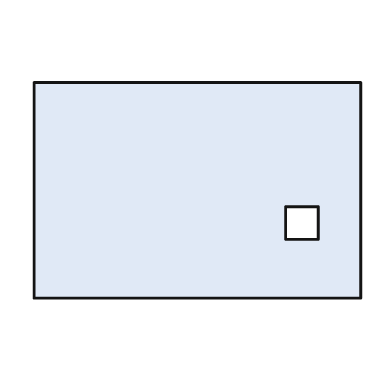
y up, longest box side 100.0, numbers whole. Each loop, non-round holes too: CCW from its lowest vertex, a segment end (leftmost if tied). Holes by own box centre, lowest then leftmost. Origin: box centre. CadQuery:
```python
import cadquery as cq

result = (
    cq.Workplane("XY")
    .moveTo(-50.0, -33.0)
    .lineTo(50.0, -33.0)
    .lineTo(50.0, 33.0)
    .lineTo(-50.0, 33.0)
    .close()
    .moveTo(27.0, -15.0)
    .lineTo(37.0, -15.0)
    .lineTo(37.0, -5.0)
    .lineTo(27.0, -5.0)
    .close()
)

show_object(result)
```